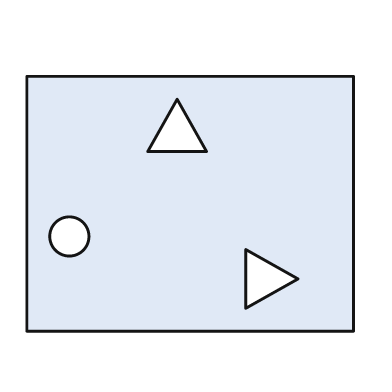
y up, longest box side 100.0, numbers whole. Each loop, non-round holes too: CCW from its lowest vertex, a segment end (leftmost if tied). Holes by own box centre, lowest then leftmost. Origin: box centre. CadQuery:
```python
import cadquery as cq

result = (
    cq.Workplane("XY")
    .moveTo(-50.0, -39.0)
    .lineTo(50.0, -39.0)
    .lineTo(50.0, 39.0)
    .lineTo(-50.0, 39.0)
    .close()
    .moveTo(17.0, -32.0)
    .lineTo(33.0, -23.0)
    .lineTo(17.0, -14.0)
    .close()
    .moveTo(-37.0, -10.0)
    .circle(6.0)
    .moveTo(-13.0, 16.0)
    .lineTo(5.0, 16.0)
    .lineTo(-4.0, 32.0)
    .close()
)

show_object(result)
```